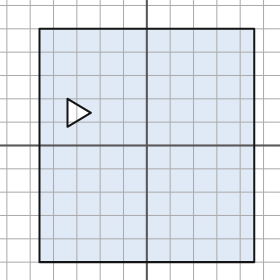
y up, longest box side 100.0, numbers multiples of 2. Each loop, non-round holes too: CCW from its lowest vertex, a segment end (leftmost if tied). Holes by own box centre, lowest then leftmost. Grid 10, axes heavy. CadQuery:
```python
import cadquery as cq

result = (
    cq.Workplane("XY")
    .moveTo(-46.0, -50.0)
    .lineTo(46.0, -50.0)
    .lineTo(46.0, 50.0)
    .lineTo(-46.0, 50.0)
    .close()
    .moveTo(-34.0, 8.0)
    .lineTo(-24.0, 14.0)
    .lineTo(-34.0, 20.0)
    .close()
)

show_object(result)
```